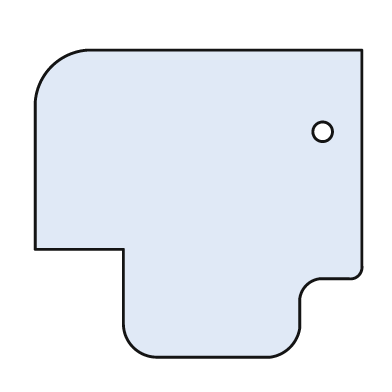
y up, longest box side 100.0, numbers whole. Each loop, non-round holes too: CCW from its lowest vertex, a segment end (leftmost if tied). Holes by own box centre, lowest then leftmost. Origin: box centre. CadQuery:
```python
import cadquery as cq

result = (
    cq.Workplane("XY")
    .moveTo(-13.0, -47.0)
    .lineTo(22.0, -47.0)
    .threePointArc((28.0, -44.0), (31.0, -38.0))
    .lineTo(31.0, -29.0)
    .threePointArc((33.0, -25.0), (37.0, -23.0))
    .lineTo(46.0, -23.0)
    .threePointArc((49.0, -22.0), (50.0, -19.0))
    .lineTo(50.0, 47.0)
    .lineTo(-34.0, 47.0)
    .threePointArc((-45.0, 42.0), (-50.0, 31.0))
    .lineTo(-50.0, -14.0)
    .lineTo(-23.0, -14.0)
    .lineTo(-23.0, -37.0)
    .threePointArc((-20.0, -44.0), (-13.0, -47.0))
    .close()
    .moveTo(38.0, 22.0)
    .circle(3.0)
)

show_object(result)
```